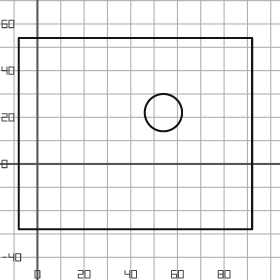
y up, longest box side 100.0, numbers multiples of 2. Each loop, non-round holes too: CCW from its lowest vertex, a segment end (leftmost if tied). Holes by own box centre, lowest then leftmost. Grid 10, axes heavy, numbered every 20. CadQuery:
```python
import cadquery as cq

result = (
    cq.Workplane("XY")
    .moveTo(-8.0, -28.0)
    .lineTo(92.0, -28.0)
    .lineTo(92.0, 54.0)
    .lineTo(-8.0, 54.0)
    .close()
    .moveTo(54.0, 22.0)
    .circle(8.0)
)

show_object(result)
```